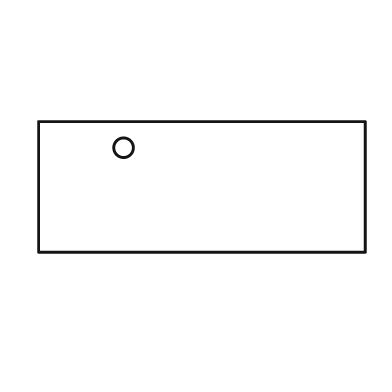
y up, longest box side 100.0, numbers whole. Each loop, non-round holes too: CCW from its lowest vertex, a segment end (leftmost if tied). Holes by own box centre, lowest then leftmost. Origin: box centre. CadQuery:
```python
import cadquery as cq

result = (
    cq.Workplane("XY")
    .moveTo(-50.0, -20.0)
    .lineTo(50.0, -20.0)
    .lineTo(50.0, 20.0)
    .lineTo(-50.0, 20.0)
    .close()
    .moveTo(-24.0, 12.0)
    .circle(3.0)
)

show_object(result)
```